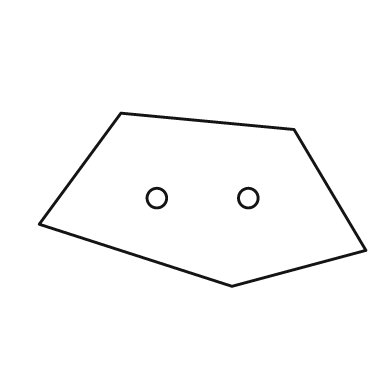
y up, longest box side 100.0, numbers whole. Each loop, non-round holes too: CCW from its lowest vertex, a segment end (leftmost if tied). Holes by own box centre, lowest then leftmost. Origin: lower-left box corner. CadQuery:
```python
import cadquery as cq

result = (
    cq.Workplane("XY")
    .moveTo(59.0, 0.0)
    .lineTo(100.0, 11.0)
    .lineTo(78.0, 48.0)
    .lineTo(25.0, 53.0)
    .lineTo(0.0, 19.0)
    .close()
    .moveTo(36.0, 27.0)
    .circle(3.0)
    .moveTo(64.0, 27.0)
    .circle(3.0)
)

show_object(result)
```